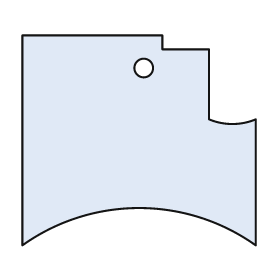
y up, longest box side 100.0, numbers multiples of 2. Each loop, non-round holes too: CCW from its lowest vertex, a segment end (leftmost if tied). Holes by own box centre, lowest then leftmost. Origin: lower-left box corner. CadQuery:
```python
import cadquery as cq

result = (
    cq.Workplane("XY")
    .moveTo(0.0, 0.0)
    .threePointArc((50.0, 16.0), (100.0, 0.0))
    .lineTo(100.0, 54.0)
    .threePointArc((90.0, 52.0), (80.0, 54.0))
    .lineTo(80.0, 84.0)
    .lineTo(60.0, 84.0)
    .lineTo(60.0, 90.0)
    .lineTo(0.0, 90.0)
    .close()
    .moveTo(52.0, 76.0)
    .circle(4.0)
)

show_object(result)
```